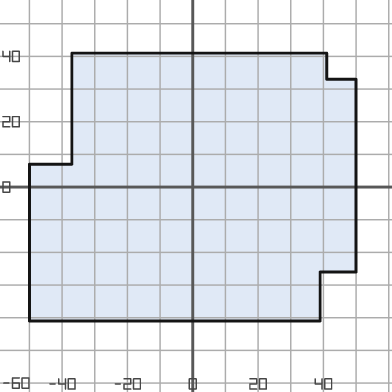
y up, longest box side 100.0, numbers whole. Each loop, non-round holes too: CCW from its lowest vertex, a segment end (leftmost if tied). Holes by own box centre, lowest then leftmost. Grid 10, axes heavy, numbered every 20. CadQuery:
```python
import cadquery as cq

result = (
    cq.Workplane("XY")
    .moveTo(-50.0, -41.0)
    .lineTo(39.0, -41.0)
    .lineTo(39.0, -26.0)
    .lineTo(50.0, -26.0)
    .lineTo(50.0, 33.0)
    .lineTo(41.0, 33.0)
    .lineTo(41.0, 41.0)
    .lineTo(-37.0, 41.0)
    .lineTo(-37.0, 7.0)
    .lineTo(-50.0, 7.0)
    .close()
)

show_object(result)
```